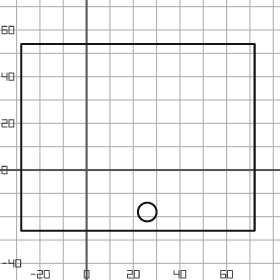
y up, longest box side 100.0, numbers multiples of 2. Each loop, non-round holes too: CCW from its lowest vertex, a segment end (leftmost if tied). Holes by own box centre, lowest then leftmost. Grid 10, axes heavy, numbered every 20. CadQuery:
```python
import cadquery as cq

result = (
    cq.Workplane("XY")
    .moveTo(-28.0, -26.0)
    .lineTo(72.0, -26.0)
    .lineTo(72.0, 54.0)
    .lineTo(-28.0, 54.0)
    .close()
    .moveTo(26.0, -18.0)
    .circle(4.0)
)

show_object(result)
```